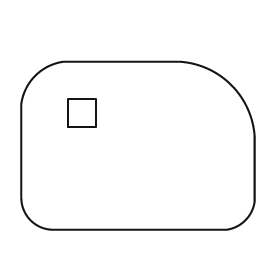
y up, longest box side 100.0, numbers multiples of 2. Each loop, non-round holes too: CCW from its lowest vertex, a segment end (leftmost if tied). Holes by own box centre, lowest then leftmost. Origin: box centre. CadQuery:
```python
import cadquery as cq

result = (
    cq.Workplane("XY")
    .moveTo(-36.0, -36.0)
    .lineTo(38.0, -36.0)
    .threePointArc((46.0, -32.0), (50.0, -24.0))
    .lineTo(50.0, 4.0)
    .threePointArc((40.0, 26.0), (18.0, 36.0))
    .lineTo(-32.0, 36.0)
    .threePointArc((-44.0, 30.0), (-50.0, 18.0))
    .lineTo(-50.0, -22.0)
    .threePointArc((-46.0, -32.0), (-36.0, -36.0))
    .close()
    .moveTo(-30.0, 8.0)
    .lineTo(-18.0, 8.0)
    .lineTo(-18.0, 20.0)
    .lineTo(-30.0, 20.0)
    .close()
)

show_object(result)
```